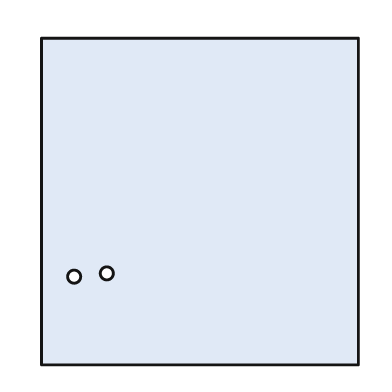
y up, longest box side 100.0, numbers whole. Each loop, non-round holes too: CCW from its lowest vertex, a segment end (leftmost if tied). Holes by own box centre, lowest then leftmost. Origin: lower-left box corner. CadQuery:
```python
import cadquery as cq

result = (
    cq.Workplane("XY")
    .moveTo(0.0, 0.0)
    .lineTo(97.0, 0.0)
    .lineTo(97.0, 100.0)
    .lineTo(0.0, 100.0)
    .close()
    .moveTo(10.0, 27.0)
    .circle(2.0)
    .moveTo(20.0, 28.0)
    .circle(2.0)
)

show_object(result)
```